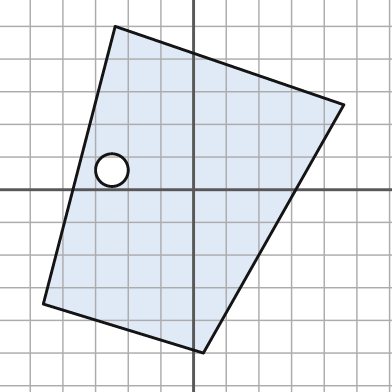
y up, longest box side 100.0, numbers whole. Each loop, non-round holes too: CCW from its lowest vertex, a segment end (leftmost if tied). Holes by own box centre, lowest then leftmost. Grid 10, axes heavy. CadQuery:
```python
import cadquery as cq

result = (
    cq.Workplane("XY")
    .moveTo(3.0, -50.0)
    .lineTo(46.0, 26.0)
    .lineTo(-24.0, 50.0)
    .lineTo(-46.0, -35.0)
    .close()
    .moveTo(-25.0, 6.0)
    .circle(5.0)
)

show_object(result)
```